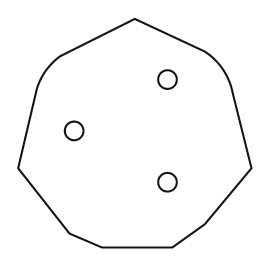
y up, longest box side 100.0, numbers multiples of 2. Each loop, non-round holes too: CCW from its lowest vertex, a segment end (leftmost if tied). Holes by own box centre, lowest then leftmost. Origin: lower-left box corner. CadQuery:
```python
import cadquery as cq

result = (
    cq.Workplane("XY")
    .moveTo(36.0, 0.0)
    .lineTo(66.0, 0.0)
    .lineTo(80.0, 10.0)
    .lineTo(100.0, 34.0)
    .lineTo(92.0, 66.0)
    .threePointArc((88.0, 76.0), (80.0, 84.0))
    .lineTo(50.0, 98.0)
    .lineTo(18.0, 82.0)
    .threePointArc((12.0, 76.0), (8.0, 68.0))
    .lineTo(0.0, 34.0)
    .lineTo(22.0, 6.0)
    .close()
    .moveTo(64.0, 28.0)
    .circle(4.0)
    .moveTo(24.0, 50.0)
    .circle(4.0)
    .moveTo(64.0, 72.0)
    .circle(4.0)
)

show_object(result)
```